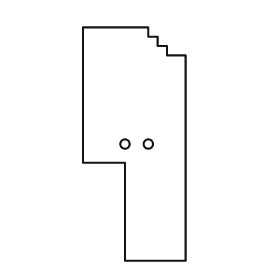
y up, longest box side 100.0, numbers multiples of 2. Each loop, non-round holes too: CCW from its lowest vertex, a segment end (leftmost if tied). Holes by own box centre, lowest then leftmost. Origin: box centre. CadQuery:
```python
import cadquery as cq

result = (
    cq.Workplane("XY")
    .moveTo(-4.0, -50.0)
    .lineTo(22.0, -50.0)
    .lineTo(22.0, 38.0)
    .lineTo(14.0, 38.0)
    .lineTo(14.0, 42.0)
    .lineTo(10.0, 42.0)
    .lineTo(10.0, 46.0)
    .lineTo(6.0, 46.0)
    .lineTo(6.0, 50.0)
    .lineTo(-22.0, 50.0)
    .lineTo(-22.0, -8.0)
    .lineTo(-4.0, -8.0)
    .close()
    .moveTo(-4.0, 0.0)
    .circle(2.0)
    .moveTo(6.0, 0.0)
    .circle(2.0)
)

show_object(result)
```